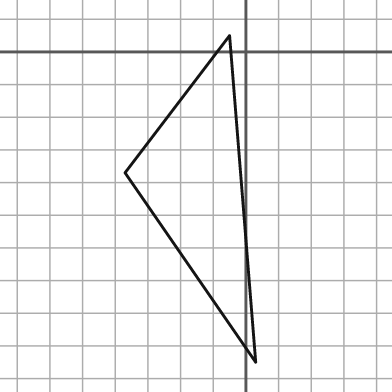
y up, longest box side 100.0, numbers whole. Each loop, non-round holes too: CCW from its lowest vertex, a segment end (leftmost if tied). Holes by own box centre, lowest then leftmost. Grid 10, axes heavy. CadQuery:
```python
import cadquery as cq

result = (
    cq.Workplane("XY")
    .moveTo(3.0, -95.0)
    .lineTo(-5.0, 5.0)
    .lineTo(-37.0, -37.0)
    .close()
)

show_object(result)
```